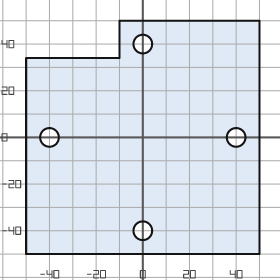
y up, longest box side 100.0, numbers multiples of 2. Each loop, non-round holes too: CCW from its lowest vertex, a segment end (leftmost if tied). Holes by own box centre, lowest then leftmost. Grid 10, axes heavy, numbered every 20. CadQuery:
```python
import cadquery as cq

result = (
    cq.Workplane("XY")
    .moveTo(-50.0, -50.0)
    .lineTo(50.0, -50.0)
    .lineTo(50.0, 50.0)
    .lineTo(-10.0, 50.0)
    .lineTo(-10.0, 34.0)
    .lineTo(-50.0, 34.0)
    .close()
    .moveTo(0.0, -40.0)
    .circle(4.0)
    .moveTo(-40.0, 0.0)
    .circle(4.0)
    .moveTo(40.0, 0.0)
    .circle(4.0)
    .moveTo(0.0, 40.0)
    .circle(4.0)
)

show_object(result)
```